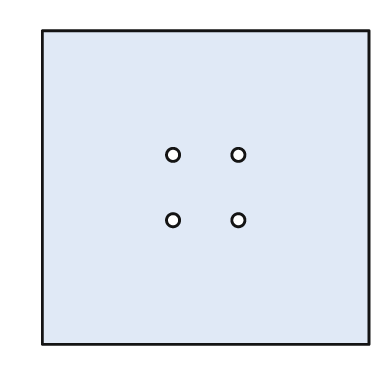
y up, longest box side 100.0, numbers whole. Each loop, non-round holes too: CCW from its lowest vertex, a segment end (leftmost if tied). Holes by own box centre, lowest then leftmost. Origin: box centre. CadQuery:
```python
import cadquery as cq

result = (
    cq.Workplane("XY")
    .moveTo(-50.0, -48.0)
    .lineTo(50.0, -48.0)
    .lineTo(50.0, 48.0)
    .lineTo(-50.0, 48.0)
    .close()
    .moveTo(-10.0, -10.0)
    .circle(2.0)
    .moveTo(10.0, -10.0)
    .circle(2.0)
    .moveTo(-10.0, 10.0)
    .circle(2.0)
    .moveTo(10.0, 10.0)
    .circle(2.0)
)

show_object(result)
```